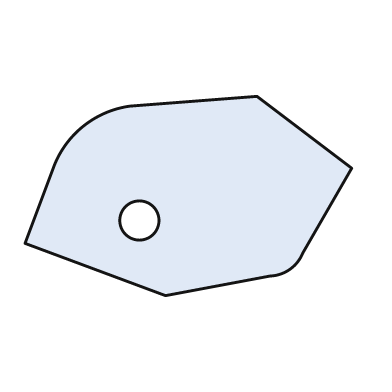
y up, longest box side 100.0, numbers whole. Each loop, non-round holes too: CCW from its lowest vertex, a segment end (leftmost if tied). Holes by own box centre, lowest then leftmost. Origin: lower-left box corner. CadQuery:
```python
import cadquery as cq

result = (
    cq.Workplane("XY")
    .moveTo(43.0, 0.0)
    .lineTo(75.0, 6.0)
    .threePointArc((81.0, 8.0), (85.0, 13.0))
    .lineTo(100.0, 39.0)
    .lineTo(71.0, 61.0)
    .lineTo(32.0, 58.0)
    .threePointArc((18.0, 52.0), (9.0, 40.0))
    .lineTo(0.0, 16.0)
    .close()
    .moveTo(35.0, 23.0)
    .circle(6.0)
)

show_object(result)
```